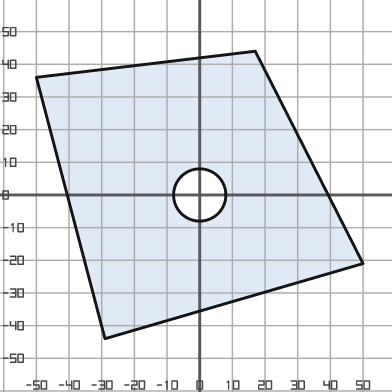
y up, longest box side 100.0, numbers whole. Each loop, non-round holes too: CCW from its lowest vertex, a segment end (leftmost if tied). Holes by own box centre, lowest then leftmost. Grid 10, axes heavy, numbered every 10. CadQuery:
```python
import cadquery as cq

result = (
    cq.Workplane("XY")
    .moveTo(-29.0, -44.0)
    .lineTo(50.0, -21.0)
    .lineTo(17.0, 44.0)
    .lineTo(-50.0, 36.0)
    .close()
    .moveTo(0.0, 0.0)
    .circle(8.0)
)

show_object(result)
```